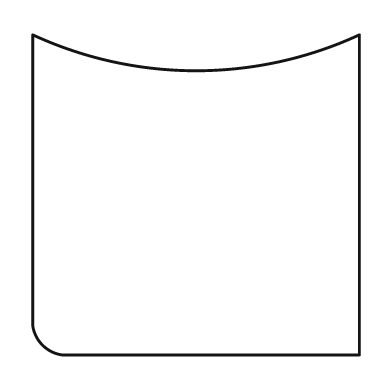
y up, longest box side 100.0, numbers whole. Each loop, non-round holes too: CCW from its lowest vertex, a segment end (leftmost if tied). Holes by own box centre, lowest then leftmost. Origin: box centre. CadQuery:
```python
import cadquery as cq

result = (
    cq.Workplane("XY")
    .moveTo(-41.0, -49.0)
    .lineTo(50.0, -49.0)
    .lineTo(50.0, 49.0)
    .threePointArc((0.0, 38.0), (-50.0, 49.0))
    .lineTo(-50.0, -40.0)
    .threePointArc((-47.0, -46.0), (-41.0, -49.0))
    .close()
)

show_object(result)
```